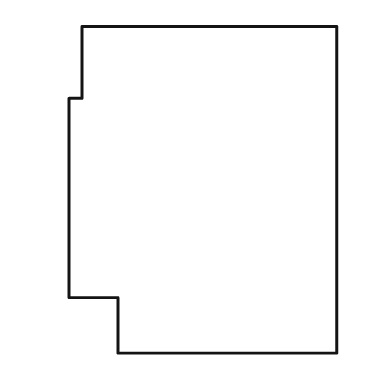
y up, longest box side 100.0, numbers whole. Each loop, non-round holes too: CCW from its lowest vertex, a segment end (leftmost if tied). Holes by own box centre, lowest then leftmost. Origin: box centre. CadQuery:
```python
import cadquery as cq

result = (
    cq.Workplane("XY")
    .moveTo(-26.0, -50.0)
    .lineTo(41.0, -50.0)
    .lineTo(41.0, 50.0)
    .lineTo(-37.0, 50.0)
    .lineTo(-37.0, 28.0)
    .lineTo(-41.0, 28.0)
    .lineTo(-41.0, -33.0)
    .lineTo(-26.0, -33.0)
    .close()
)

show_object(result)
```